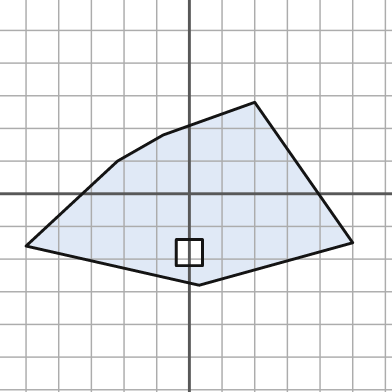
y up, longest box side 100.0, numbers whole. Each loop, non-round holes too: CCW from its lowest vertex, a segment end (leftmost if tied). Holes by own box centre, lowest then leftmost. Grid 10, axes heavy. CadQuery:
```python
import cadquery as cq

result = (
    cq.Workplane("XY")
    .moveTo(3.0, -28.0)
    .lineTo(50.0, -15.0)
    .lineTo(20.0, 28.0)
    .lineTo(-8.0, 18.0)
    .lineTo(-22.0, 10.0)
    .lineTo(-50.0, -16.0)
    .close()
    .moveTo(-4.0, -22.0)
    .lineTo(4.0, -22.0)
    .lineTo(4.0, -14.0)
    .lineTo(-4.0, -14.0)
    .close()
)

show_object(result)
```